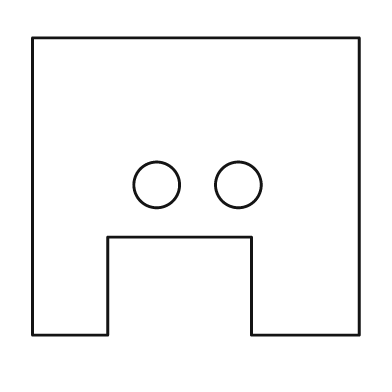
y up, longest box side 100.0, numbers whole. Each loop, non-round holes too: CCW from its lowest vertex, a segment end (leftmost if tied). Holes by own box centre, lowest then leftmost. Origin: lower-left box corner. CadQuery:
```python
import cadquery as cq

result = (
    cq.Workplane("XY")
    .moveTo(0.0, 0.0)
    .lineTo(23.0, 0.0)
    .lineTo(23.0, 30.0)
    .lineTo(67.0, 30.0)
    .lineTo(67.0, 0.0)
    .lineTo(100.0, 0.0)
    .lineTo(100.0, 91.0)
    .lineTo(0.0, 91.0)
    .close()
    .moveTo(38.0, 46.0)
    .circle(7.0)
    .moveTo(63.0, 46.0)
    .circle(7.0)
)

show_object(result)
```